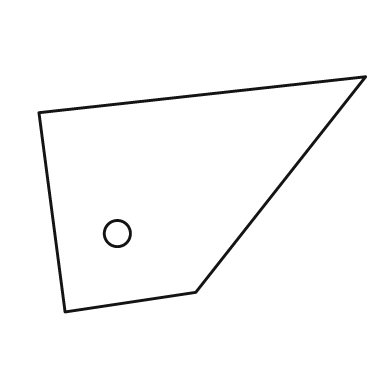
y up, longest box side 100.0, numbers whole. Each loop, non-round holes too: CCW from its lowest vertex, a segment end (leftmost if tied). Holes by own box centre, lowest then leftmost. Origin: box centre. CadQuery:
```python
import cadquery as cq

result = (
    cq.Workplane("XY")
    .moveTo(-42.0, -36.0)
    .lineTo(-2.0, -30.0)
    .lineTo(50.0, 36.0)
    .lineTo(-50.0, 25.0)
    .close()
    .moveTo(-26.0, -12.0)
    .circle(4.0)
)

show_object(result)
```